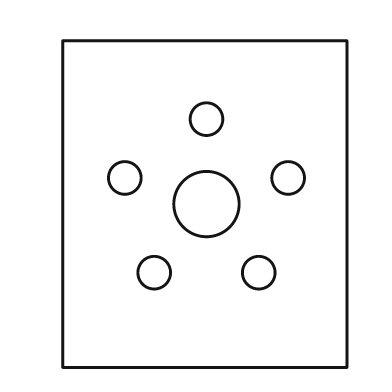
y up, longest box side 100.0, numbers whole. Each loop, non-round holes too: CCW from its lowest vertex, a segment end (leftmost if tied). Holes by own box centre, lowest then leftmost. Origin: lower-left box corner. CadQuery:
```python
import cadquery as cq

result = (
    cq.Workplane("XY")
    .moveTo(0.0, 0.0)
    .lineTo(87.0, 0.0)
    .lineTo(87.0, 100.0)
    .lineTo(0.0, 100.0)
    .close()
    .moveTo(28.0, 29.0)
    .circle(5.0)
    .moveTo(60.0, 29.0)
    .circle(5.0)
    .moveTo(44.0, 50.0)
    .circle(10.0)
    .moveTo(19.0, 58.0)
    .circle(5.0)
    .moveTo(69.0, 58.0)
    .circle(5.0)
    .moveTo(44.0, 76.0)
    .circle(5.0)
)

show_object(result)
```